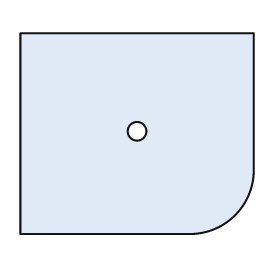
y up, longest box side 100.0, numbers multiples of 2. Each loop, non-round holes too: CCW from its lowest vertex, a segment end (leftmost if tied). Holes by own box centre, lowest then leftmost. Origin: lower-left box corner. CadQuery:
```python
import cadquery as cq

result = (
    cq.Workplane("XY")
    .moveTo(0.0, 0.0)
    .lineTo(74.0, 0.0)
    .threePointArc((92.0, 8.0), (100.0, 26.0))
    .lineTo(100.0, 86.0)
    .lineTo(0.0, 86.0)
    .close()
    .moveTo(50.0, 44.0)
    .circle(4.0)
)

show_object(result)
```